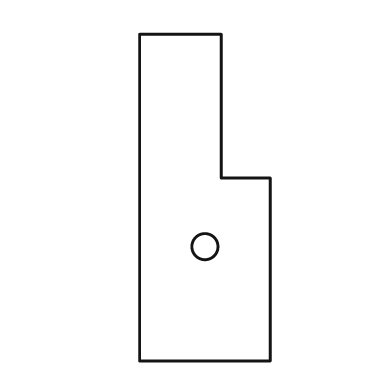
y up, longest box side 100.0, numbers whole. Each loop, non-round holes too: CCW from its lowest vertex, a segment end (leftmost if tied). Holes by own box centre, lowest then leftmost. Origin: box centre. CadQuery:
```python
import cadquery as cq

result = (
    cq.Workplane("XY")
    .moveTo(-20.0, -50.0)
    .lineTo(20.0, -50.0)
    .lineTo(20.0, 6.0)
    .lineTo(5.0, 6.0)
    .lineTo(5.0, 50.0)
    .lineTo(-20.0, 50.0)
    .close()
    .moveTo(0.0, -15.0)
    .circle(4.0)
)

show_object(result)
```